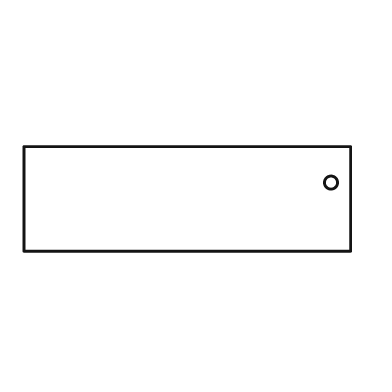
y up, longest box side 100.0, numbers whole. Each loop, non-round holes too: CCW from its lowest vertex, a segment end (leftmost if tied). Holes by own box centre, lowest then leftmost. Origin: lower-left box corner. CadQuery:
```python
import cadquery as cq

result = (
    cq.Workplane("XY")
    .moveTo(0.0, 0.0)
    .lineTo(100.0, 0.0)
    .lineTo(100.0, 32.0)
    .lineTo(0.0, 32.0)
    .close()
    .moveTo(94.0, 21.0)
    .circle(2.0)
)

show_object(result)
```